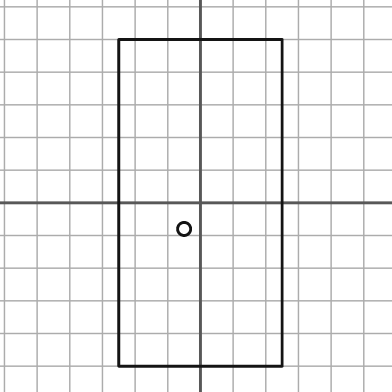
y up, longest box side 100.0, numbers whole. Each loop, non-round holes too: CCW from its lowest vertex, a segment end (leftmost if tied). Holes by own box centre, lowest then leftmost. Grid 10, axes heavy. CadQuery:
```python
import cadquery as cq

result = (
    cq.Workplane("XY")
    .moveTo(-25.0, -50.0)
    .lineTo(25.0, -50.0)
    .lineTo(25.0, 50.0)
    .lineTo(-25.0, 50.0)
    .close()
    .moveTo(-5.0, -8.0)
    .circle(2.0)
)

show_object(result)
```